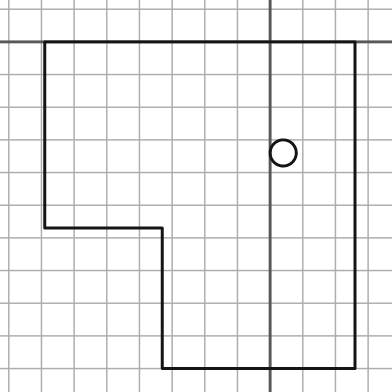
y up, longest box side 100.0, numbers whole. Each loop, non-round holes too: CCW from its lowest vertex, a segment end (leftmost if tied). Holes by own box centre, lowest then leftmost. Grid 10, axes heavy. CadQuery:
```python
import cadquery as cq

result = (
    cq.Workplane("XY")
    .moveTo(-33.0, -100.0)
    .lineTo(26.0, -100.0)
    .lineTo(26.0, 0.0)
    .lineTo(-69.0, 0.0)
    .lineTo(-69.0, -57.0)
    .lineTo(-33.0, -57.0)
    .close()
    .moveTo(4.0, -34.0)
    .circle(4.0)
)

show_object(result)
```